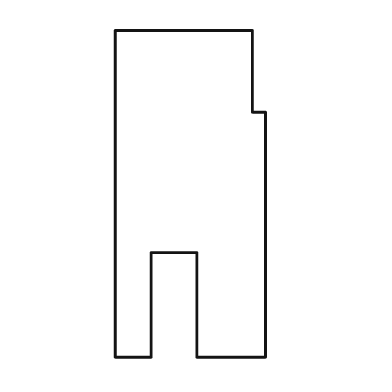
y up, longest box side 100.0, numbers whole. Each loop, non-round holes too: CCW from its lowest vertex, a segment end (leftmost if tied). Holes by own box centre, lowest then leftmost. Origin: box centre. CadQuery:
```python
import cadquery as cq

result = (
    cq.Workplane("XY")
    .moveTo(-23.0, -50.0)
    .lineTo(-12.0, -50.0)
    .lineTo(-12.0, -18.0)
    .lineTo(2.0, -18.0)
    .lineTo(2.0, -50.0)
    .lineTo(23.0, -50.0)
    .lineTo(23.0, 25.0)
    .lineTo(19.0, 25.0)
    .lineTo(19.0, 50.0)
    .lineTo(-23.0, 50.0)
    .close()
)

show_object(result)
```